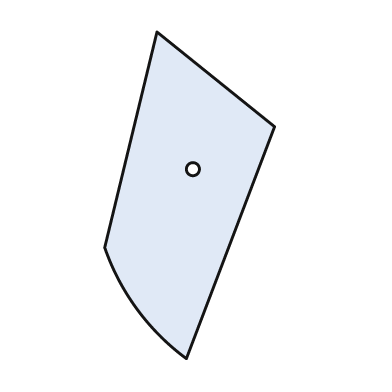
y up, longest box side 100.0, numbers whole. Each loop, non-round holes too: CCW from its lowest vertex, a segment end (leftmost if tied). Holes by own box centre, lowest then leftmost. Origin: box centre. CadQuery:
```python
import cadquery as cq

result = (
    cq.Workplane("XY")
    .moveTo(-1.0, -50.0)
    .lineTo(26.0, 21.0)
    .lineTo(-10.0, 50.0)
    .lineTo(-26.0, -16.0)
    .threePointArc((-16.0, -35.0), (-1.0, -50.0))
    .close()
    .moveTo(1.0, 8.0)
    .circle(2.0)
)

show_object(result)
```